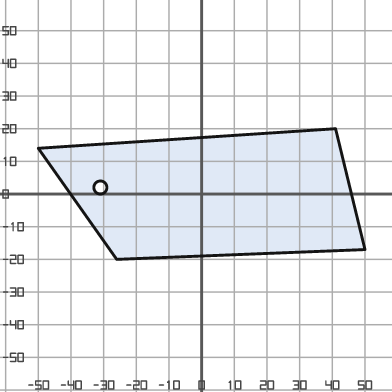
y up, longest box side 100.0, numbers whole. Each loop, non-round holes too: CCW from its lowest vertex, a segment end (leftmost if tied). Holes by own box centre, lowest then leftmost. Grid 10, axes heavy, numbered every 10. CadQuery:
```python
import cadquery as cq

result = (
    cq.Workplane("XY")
    .moveTo(-26.0, -20.0)
    .lineTo(50.0, -17.0)
    .lineTo(41.0, 20.0)
    .lineTo(-50.0, 14.0)
    .close()
    .moveTo(-31.0, 2.0)
    .circle(2.0)
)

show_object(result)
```